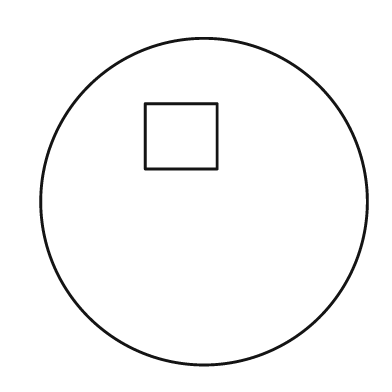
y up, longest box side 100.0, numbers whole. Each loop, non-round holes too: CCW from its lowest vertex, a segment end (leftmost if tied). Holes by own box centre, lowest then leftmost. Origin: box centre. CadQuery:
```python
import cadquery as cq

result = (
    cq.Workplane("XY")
    .moveTo(0.0, 0.0)
    .circle(50.0)
    .moveTo(-18.0, 10.0)
    .lineTo(4.0, 10.0)
    .lineTo(4.0, 30.0)
    .lineTo(-18.0, 30.0)
    .close()
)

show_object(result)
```